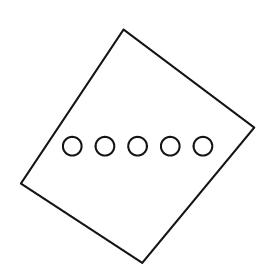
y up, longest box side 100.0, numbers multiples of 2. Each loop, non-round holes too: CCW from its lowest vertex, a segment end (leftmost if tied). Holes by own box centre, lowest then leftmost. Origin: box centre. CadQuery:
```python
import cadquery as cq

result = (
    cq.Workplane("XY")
    .moveTo(2.0, -50.0)
    .lineTo(50.0, 8.0)
    .lineTo(-6.0, 50.0)
    .lineTo(-50.0, -16.0)
    .close()
    .moveTo(-28.0, 0.0)
    .circle(4.0)
    .moveTo(-14.0, 0.0)
    .circle(4.0)
    .moveTo(0.0, 0.0)
    .circle(4.0)
    .moveTo(14.0, 0.0)
    .circle(4.0)
    .moveTo(28.0, 0.0)
    .circle(4.0)
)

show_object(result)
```